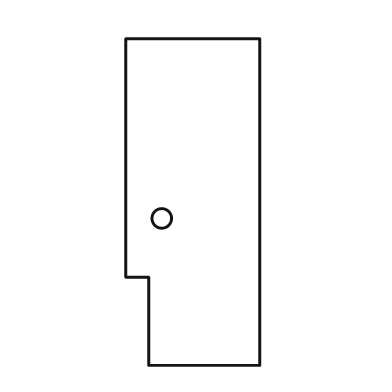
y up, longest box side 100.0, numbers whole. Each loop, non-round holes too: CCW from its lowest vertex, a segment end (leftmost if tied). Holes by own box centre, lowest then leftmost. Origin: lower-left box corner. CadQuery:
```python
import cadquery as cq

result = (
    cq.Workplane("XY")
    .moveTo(7.0, 0.0)
    .lineTo(41.0, 0.0)
    .lineTo(41.0, 100.0)
    .lineTo(0.0, 100.0)
    .lineTo(0.0, 27.0)
    .lineTo(7.0, 27.0)
    .close()
    .moveTo(11.0, 45.0)
    .circle(3.0)
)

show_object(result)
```